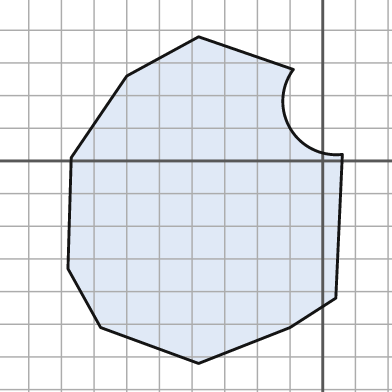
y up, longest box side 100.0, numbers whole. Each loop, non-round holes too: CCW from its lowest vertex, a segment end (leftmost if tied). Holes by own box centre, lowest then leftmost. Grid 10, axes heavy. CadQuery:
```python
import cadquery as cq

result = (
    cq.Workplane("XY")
    .moveTo(-38.0, -62.0)
    .lineTo(-10.0, -51.0)
    .lineTo(4.0, -42.0)
    .lineTo(6.0, 2.0)
    .threePointArc((-10.0, 10.0), (-9.0, 28.0))
    .lineTo(-38.0, 38.0)
    .lineTo(-60.0, 26.0)
    .lineTo(-77.0, 1.0)
    .lineTo(-78.0, -33.0)
    .lineTo(-68.0, -51.0)
    .close()
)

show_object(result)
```